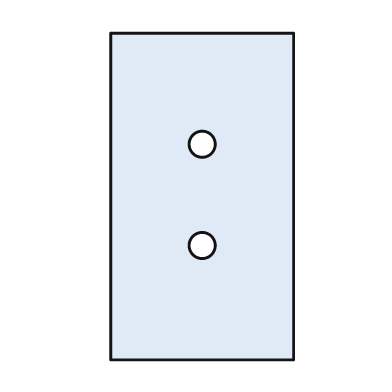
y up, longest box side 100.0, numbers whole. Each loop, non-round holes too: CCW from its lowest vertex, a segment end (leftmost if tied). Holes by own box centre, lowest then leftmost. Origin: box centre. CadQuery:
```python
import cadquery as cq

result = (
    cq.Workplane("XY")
    .moveTo(-28.0, -50.0)
    .lineTo(28.0, -50.0)
    .lineTo(28.0, 50.0)
    .lineTo(-28.0, 50.0)
    .close()
    .moveTo(0.0, -15.0)
    .circle(4.0)
    .moveTo(0.0, 16.0)
    .circle(4.0)
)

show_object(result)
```